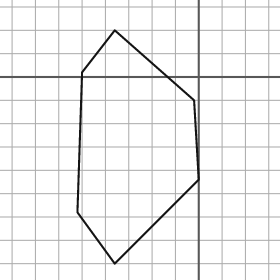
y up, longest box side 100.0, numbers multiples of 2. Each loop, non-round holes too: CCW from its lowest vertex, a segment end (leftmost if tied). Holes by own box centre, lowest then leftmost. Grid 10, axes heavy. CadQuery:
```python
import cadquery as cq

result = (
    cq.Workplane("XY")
    .moveTo(-36.0, -80.0)
    .lineTo(0.0, -44.0)
    .lineTo(-2.0, -10.0)
    .lineTo(-36.0, 20.0)
    .lineTo(-50.0, 2.0)
    .lineTo(-52.0, -58.0)
    .close()
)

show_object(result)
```